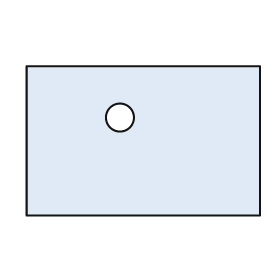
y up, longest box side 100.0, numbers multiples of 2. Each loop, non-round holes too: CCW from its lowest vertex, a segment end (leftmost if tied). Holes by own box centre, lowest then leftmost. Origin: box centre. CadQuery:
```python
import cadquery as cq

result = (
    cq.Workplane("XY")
    .moveTo(-50.0, -32.0)
    .lineTo(50.0, -32.0)
    .lineTo(50.0, 32.0)
    .lineTo(-50.0, 32.0)
    .close()
    .moveTo(-10.0, 10.0)
    .circle(6.0)
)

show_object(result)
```